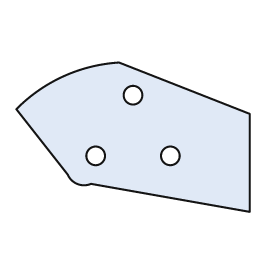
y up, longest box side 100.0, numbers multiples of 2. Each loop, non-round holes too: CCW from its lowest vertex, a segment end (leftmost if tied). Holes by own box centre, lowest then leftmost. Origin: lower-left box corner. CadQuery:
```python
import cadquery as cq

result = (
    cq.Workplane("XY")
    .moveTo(100.0, 0.0)
    .lineTo(100.0, 42.0)
    .lineTo(44.0, 64.0)
    .threePointArc((20.0, 58.0), (0.0, 44.0))
    .lineTo(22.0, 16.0)
    .threePointArc((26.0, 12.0), (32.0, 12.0))
    .close()
    .moveTo(34.0, 24.0)
    .circle(4.0)
    .moveTo(66.0, 24.0)
    .circle(4.0)
    .moveTo(50.0, 50.0)
    .circle(4.0)
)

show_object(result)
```